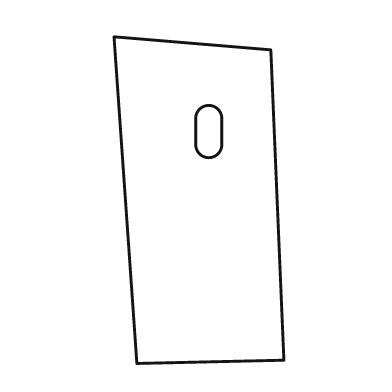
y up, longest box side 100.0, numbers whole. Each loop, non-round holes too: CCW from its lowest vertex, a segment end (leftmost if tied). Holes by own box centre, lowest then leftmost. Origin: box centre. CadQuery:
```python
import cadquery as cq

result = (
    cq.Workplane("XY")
    .moveTo(-19.0, -50.0)
    .lineTo(26.0, -49.0)
    .lineTo(22.0, 46.0)
    .lineTo(-26.0, 50.0)
    .close()
    .moveTo(-1.0, 17.0)
    .threePointArc((3.0, 13.0), (7.0, 17.0))
    .lineTo(7.0, 25.0)
    .threePointArc((3.0, 29.0), (-1.0, 25.0))
    .close()
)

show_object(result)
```